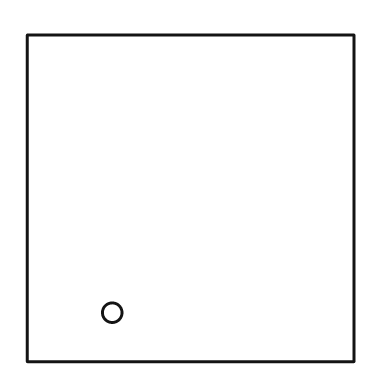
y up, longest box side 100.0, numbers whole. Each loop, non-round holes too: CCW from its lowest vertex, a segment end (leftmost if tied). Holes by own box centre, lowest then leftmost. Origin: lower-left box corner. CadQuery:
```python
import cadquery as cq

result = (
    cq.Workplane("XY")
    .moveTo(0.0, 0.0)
    .lineTo(100.0, 0.0)
    .lineTo(100.0, 100.0)
    .lineTo(0.0, 100.0)
    .close()
    .moveTo(26.0, 15.0)
    .circle(3.0)
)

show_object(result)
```